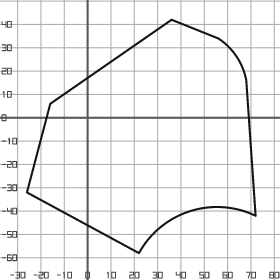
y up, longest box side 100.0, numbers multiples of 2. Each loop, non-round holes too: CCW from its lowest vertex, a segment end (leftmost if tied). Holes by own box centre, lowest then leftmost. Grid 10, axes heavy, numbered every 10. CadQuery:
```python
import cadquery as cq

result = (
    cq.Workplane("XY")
    .moveTo(22.0, -58.0)
    .threePointArc((44.0, -40.0), (72.0, -42.0))
    .lineTo(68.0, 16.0)
    .threePointArc((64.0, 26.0), (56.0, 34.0))
    .lineTo(36.0, 42.0)
    .lineTo(-16.0, 6.0)
    .lineTo(-26.0, -32.0)
    .close()
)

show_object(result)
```